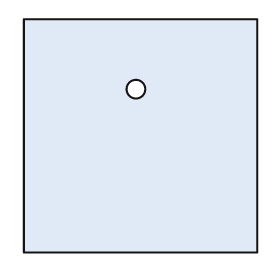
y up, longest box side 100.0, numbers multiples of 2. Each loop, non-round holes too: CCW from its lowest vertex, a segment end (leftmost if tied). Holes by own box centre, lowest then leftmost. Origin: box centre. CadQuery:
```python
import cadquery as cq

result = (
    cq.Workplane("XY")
    .moveTo(-50.0, -50.0)
    .lineTo(50.0, -50.0)
    .lineTo(50.0, 50.0)
    .lineTo(-50.0, 50.0)
    .close()
    .moveTo(-2.0, 20.0)
    .circle(4.0)
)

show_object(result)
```